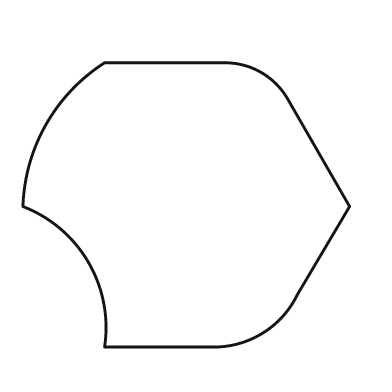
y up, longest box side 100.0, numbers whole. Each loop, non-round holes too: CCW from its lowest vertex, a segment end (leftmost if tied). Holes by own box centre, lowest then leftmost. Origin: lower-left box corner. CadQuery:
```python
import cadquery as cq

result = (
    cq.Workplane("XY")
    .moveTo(25.0, 0.0)
    .lineTo(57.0, 0.0)
    .threePointArc((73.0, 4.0), (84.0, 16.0))
    .lineTo(100.0, 43.0)
    .lineTo(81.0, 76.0)
    .threePointArc((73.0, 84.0), (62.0, 87.0))
    .lineTo(25.0, 87.0)
    .threePointArc((7.0, 68.0), (0.0, 43.0))
    .threePointArc((20.0, 26.0), (25.0, 0.0))
    .close()
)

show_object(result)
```